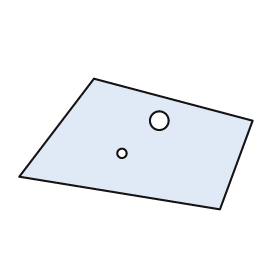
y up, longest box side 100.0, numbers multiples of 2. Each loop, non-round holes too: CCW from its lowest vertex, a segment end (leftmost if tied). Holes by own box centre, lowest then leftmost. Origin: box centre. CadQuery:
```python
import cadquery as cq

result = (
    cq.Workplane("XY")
    .moveTo(36.0, -28.0)
    .lineTo(50.0, 10.0)
    .lineTo(-18.0, 28.0)
    .lineTo(-50.0, -14.0)
    .close()
    .moveTo(-6.0, -4.0)
    .circle(2.0)
    .moveTo(10.0, 10.0)
    .circle(4.0)
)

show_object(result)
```